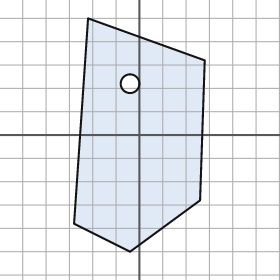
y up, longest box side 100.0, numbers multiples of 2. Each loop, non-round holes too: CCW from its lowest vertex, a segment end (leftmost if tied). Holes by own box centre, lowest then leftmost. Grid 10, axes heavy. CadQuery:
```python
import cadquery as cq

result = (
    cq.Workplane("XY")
    .moveTo(-4.0, -50.0)
    .lineTo(26.0, -28.0)
    .lineTo(28.0, 32.0)
    .lineTo(-22.0, 50.0)
    .lineTo(-28.0, -38.0)
    .close()
    .moveTo(-4.0, 22.0)
    .circle(4.0)
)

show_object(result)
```